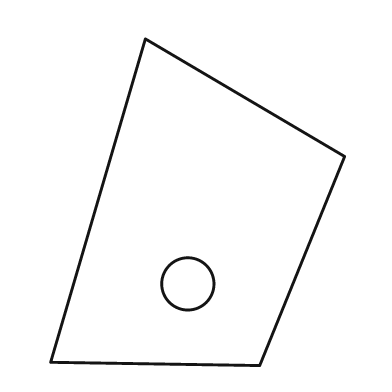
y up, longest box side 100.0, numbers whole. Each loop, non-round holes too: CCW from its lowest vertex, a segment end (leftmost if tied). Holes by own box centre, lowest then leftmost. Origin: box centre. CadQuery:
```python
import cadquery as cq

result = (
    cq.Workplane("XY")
    .moveTo(19.0, -50.0)
    .lineTo(45.0, 14.0)
    .lineTo(-16.0, 50.0)
    .lineTo(-45.0, -49.0)
    .close()
    .moveTo(-3.0, -25.0)
    .circle(8.0)
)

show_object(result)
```